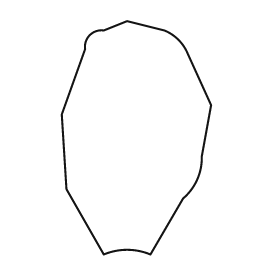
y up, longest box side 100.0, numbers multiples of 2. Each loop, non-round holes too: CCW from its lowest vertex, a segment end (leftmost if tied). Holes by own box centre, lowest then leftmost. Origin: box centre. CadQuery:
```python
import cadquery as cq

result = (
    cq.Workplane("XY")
    .moveTo(-14.0, -50.0)
    .threePointArc((-4.0, -48.0), (6.0, -50.0))
    .lineTo(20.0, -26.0)
    .threePointArc((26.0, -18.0), (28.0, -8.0))
    .lineTo(32.0, 14.0)
    .lineTo(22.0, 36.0)
    .threePointArc((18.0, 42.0), (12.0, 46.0))
    .lineTo(-4.0, 50.0)
    .lineTo(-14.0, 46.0)
    .threePointArc((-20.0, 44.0), (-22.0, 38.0))
    .lineTo(-32.0, 10.0)
    .lineTo(-30.0, -22.0)
    .close()
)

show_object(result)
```